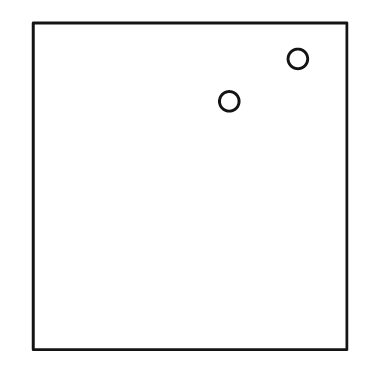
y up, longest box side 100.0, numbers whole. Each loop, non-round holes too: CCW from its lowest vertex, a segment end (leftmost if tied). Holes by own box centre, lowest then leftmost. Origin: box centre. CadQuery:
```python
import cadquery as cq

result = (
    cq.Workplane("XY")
    .moveTo(-48.0, -50.0)
    .lineTo(48.0, -50.0)
    .lineTo(48.0, 50.0)
    .lineTo(-48.0, 50.0)
    .close()
    .moveTo(12.0, 26.0)
    .circle(3.0)
    .moveTo(33.0, 39.0)
    .circle(3.0)
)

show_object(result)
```